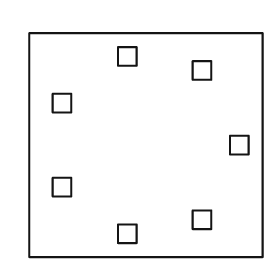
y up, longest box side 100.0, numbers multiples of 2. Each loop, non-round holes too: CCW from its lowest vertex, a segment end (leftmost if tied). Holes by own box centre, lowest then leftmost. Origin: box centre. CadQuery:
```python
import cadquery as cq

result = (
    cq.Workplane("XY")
    .moveTo(-50.0, -48.0)
    .lineTo(50.0, -48.0)
    .lineTo(50.0, 48.0)
    .lineTo(-50.0, 48.0)
    .close()
    .moveTo(-12.0, -42.0)
    .lineTo(-4.0, -42.0)
    .lineTo(-4.0, -34.0)
    .lineTo(-12.0, -34.0)
    .close()
    .moveTo(20.0, -36.0)
    .lineTo(28.0, -36.0)
    .lineTo(28.0, -28.0)
    .lineTo(20.0, -28.0)
    .close()
    .moveTo(-40.0, -22.0)
    .lineTo(-32.0, -22.0)
    .lineTo(-32.0, -14.0)
    .lineTo(-40.0, -14.0)
    .close()
    .moveTo(36.0, -4.0)
    .lineTo(44.0, -4.0)
    .lineTo(44.0, 4.0)
    .lineTo(36.0, 4.0)
    .close()
    .moveTo(-40.0, 14.0)
    .lineTo(-32.0, 14.0)
    .lineTo(-32.0, 22.0)
    .lineTo(-40.0, 22.0)
    .close()
    .moveTo(20.0, 28.0)
    .lineTo(28.0, 28.0)
    .lineTo(28.0, 36.0)
    .lineTo(20.0, 36.0)
    .close()
    .moveTo(-12.0, 34.0)
    .lineTo(-4.0, 34.0)
    .lineTo(-4.0, 42.0)
    .lineTo(-12.0, 42.0)
    .close()
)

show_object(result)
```